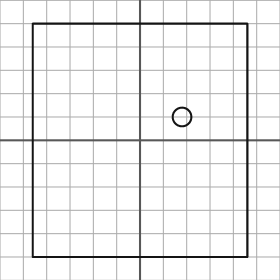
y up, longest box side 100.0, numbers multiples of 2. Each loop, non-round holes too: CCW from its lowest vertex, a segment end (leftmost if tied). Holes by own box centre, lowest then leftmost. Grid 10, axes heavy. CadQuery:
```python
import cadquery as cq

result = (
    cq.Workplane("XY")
    .moveTo(-46.0, -50.0)
    .lineTo(46.0, -50.0)
    .lineTo(46.0, 50.0)
    .lineTo(-46.0, 50.0)
    .close()
    .moveTo(18.0, 10.0)
    .circle(4.0)
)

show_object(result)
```